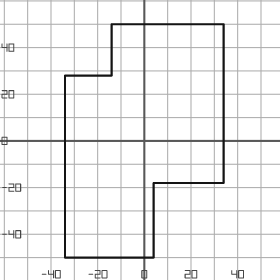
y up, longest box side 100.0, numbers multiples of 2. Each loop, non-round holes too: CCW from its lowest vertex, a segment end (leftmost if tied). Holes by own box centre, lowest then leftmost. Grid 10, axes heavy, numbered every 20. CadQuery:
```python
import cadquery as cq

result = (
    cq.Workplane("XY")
    .moveTo(-34.0, -50.0)
    .lineTo(4.0, -50.0)
    .lineTo(4.0, -18.0)
    .lineTo(34.0, -18.0)
    .lineTo(34.0, 50.0)
    .lineTo(-14.0, 50.0)
    .lineTo(-14.0, 28.0)
    .lineTo(-34.0, 28.0)
    .close()
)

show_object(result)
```